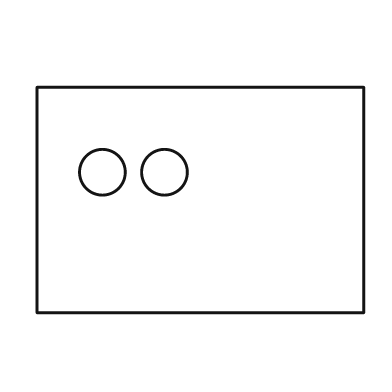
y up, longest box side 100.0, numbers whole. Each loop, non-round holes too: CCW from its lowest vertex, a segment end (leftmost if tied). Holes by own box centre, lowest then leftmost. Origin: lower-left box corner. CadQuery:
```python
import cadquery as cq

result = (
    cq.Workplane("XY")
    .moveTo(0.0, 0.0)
    .lineTo(100.0, 0.0)
    .lineTo(100.0, 69.0)
    .lineTo(0.0, 69.0)
    .close()
    .moveTo(20.0, 43.0)
    .circle(7.0)
    .moveTo(39.0, 43.0)
    .circle(7.0)
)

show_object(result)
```